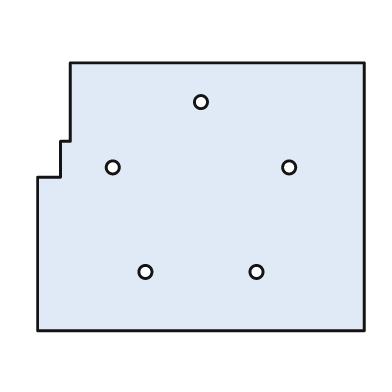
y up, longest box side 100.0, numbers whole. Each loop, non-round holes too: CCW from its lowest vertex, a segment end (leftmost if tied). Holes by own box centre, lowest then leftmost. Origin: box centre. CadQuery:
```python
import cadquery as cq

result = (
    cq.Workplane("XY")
    .moveTo(-50.0, -41.0)
    .lineTo(50.0, -41.0)
    .lineTo(50.0, 41.0)
    .lineTo(-40.0, 41.0)
    .lineTo(-40.0, 17.0)
    .lineTo(-43.0, 17.0)
    .lineTo(-43.0, 6.0)
    .lineTo(-50.0, 6.0)
    .close()
    .moveTo(-17.0, -23.0)
    .circle(2.0)
    .moveTo(17.0, -23.0)
    .circle(2.0)
    .moveTo(-27.0, 9.0)
    .circle(2.0)
    .moveTo(27.0, 9.0)
    .circle(2.0)
    .moveTo(0.0, 29.0)
    .circle(2.0)
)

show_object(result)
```